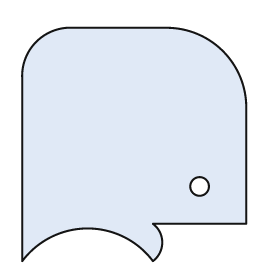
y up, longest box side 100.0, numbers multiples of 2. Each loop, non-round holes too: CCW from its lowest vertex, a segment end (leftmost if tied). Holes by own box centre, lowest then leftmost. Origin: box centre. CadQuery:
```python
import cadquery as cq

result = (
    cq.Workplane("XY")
    .moveTo(-48.0, -50.0)
    .threePointArc((-20.0, -36.0), (8.0, -50.0))
    .threePointArc((12.0, -42.0), (8.0, -34.0))
    .lineTo(48.0, -34.0)
    .lineTo(48.0, 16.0)
    .threePointArc((38.0, 40.0), (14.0, 50.0))
    .lineTo(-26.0, 50.0)
    .threePointArc((-42.0, 44.0), (-48.0, 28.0))
    .close()
    .moveTo(28.0, -18.0)
    .circle(4.0)
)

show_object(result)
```